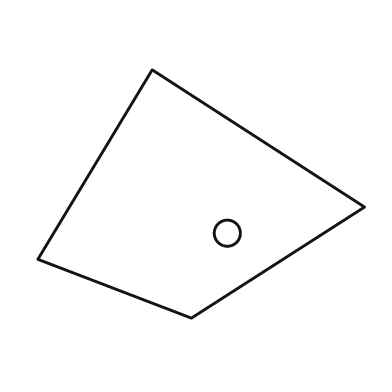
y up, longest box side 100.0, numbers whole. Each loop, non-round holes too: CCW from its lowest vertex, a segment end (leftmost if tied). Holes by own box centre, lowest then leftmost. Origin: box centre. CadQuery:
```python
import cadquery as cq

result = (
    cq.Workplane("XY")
    .moveTo(-3.0, -38.0)
    .lineTo(50.0, -4.0)
    .lineTo(-15.0, 38.0)
    .lineTo(-50.0, -20.0)
    .close()
    .moveTo(8.0, -12.0)
    .circle(4.0)
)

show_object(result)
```